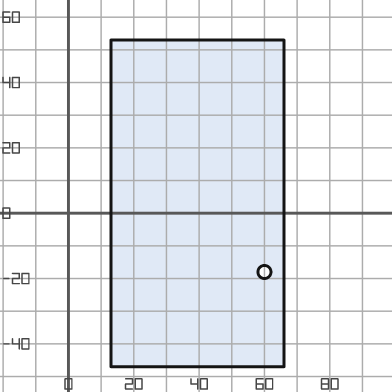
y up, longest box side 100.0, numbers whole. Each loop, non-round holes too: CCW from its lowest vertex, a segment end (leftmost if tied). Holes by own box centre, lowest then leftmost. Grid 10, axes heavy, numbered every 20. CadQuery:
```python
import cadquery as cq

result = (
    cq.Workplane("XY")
    .moveTo(13.0, -47.0)
    .lineTo(66.0, -47.0)
    .lineTo(66.0, 53.0)
    .lineTo(13.0, 53.0)
    .close()
    .moveTo(60.0, -18.0)
    .circle(2.0)
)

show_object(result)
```